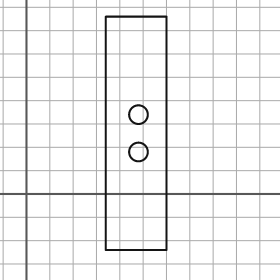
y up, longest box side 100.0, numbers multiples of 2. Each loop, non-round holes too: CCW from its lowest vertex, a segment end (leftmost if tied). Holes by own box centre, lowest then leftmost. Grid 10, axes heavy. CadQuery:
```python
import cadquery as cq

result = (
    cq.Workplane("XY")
    .moveTo(34.0, -24.0)
    .lineTo(60.0, -24.0)
    .lineTo(60.0, 76.0)
    .lineTo(34.0, 76.0)
    .close()
    .moveTo(48.0, 18.0)
    .circle(4.0)
    .moveTo(48.0, 34.0)
    .circle(4.0)
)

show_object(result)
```